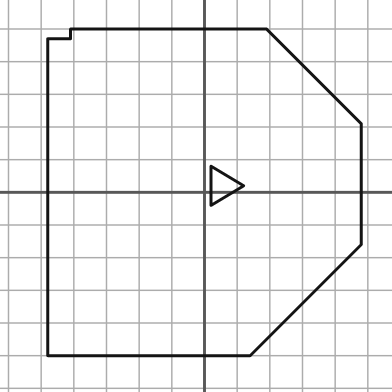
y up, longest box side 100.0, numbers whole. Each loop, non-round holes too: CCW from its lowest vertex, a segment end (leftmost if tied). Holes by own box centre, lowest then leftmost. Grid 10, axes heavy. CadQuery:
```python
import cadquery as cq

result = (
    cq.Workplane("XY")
    .moveTo(-48.0, -50.0)
    .lineTo(14.0, -50.0)
    .lineTo(48.0, -16.0)
    .lineTo(48.0, 21.0)
    .lineTo(19.0, 50.0)
    .lineTo(-41.0, 50.0)
    .lineTo(-41.0, 47.0)
    .lineTo(-48.0, 47.0)
    .close()
    .moveTo(2.0, -4.0)
    .lineTo(12.0, 2.0)
    .lineTo(2.0, 8.0)
    .close()
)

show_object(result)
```